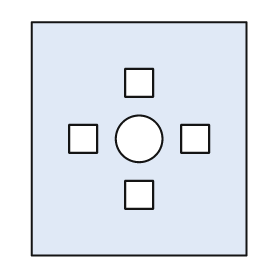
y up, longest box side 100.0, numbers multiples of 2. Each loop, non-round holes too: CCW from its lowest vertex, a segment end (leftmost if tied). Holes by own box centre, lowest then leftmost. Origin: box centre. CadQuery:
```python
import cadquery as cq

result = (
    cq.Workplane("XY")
    .moveTo(-46.0, -50.0)
    .lineTo(46.0, -50.0)
    .lineTo(46.0, 50.0)
    .lineTo(-46.0, 50.0)
    .close()
    .moveTo(-6.0, -30.0)
    .lineTo(6.0, -30.0)
    .lineTo(6.0, -18.0)
    .lineTo(-6.0, -18.0)
    .close()
    .moveTo(-30.0, -6.0)
    .lineTo(-18.0, -6.0)
    .lineTo(-18.0, 6.0)
    .lineTo(-30.0, 6.0)
    .close()
    .moveTo(0.0, 0.0)
    .circle(10.0)
    .moveTo(18.0, -6.0)
    .lineTo(30.0, -6.0)
    .lineTo(30.0, 6.0)
    .lineTo(18.0, 6.0)
    .close()
    .moveTo(-6.0, 18.0)
    .lineTo(6.0, 18.0)
    .lineTo(6.0, 30.0)
    .lineTo(-6.0, 30.0)
    .close()
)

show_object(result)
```